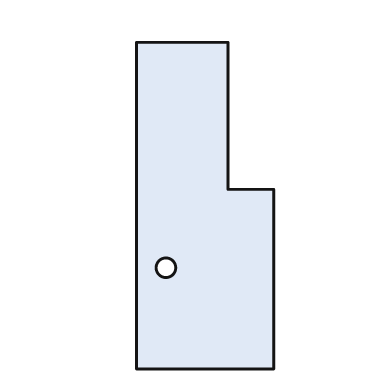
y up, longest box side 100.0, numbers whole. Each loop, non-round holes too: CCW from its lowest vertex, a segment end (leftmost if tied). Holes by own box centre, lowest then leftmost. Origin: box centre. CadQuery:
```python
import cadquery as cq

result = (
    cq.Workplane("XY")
    .moveTo(-21.0, -50.0)
    .lineTo(21.0, -50.0)
    .lineTo(21.0, 5.0)
    .lineTo(7.0, 5.0)
    .lineTo(7.0, 50.0)
    .lineTo(-21.0, 50.0)
    .close()
    .moveTo(-12.0, -19.0)
    .circle(3.0)
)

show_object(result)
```